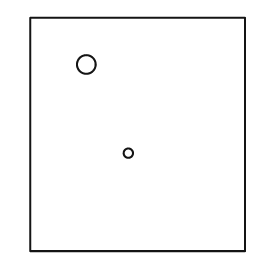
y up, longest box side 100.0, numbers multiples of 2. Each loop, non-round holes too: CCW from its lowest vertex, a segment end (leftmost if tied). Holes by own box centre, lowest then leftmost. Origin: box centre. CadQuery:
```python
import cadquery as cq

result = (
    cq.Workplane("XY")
    .moveTo(-46.0, -50.0)
    .lineTo(46.0, -50.0)
    .lineTo(46.0, 50.0)
    .lineTo(-46.0, 50.0)
    .close()
    .moveTo(-4.0, -8.0)
    .circle(2.0)
    .moveTo(-22.0, 30.0)
    .circle(4.0)
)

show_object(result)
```